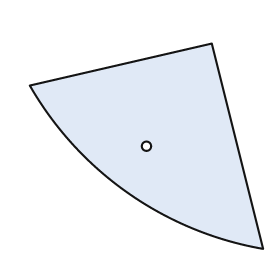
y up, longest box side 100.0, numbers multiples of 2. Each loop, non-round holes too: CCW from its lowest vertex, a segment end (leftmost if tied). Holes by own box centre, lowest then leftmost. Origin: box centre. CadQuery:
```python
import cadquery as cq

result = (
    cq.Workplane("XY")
    .moveTo(50.0, -44.0)
    .lineTo(28.0, 44.0)
    .lineTo(-50.0, 26.0)
    .threePointArc((-8.0, -20.0), (50.0, -44.0))
    .close()
    .moveTo(0.0, 0.0)
    .circle(2.0)
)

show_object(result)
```